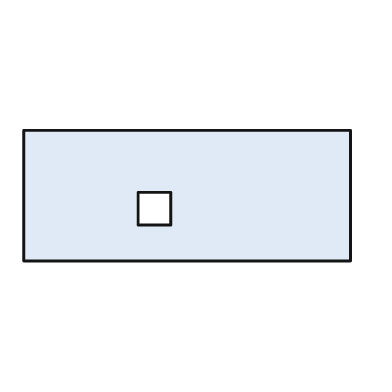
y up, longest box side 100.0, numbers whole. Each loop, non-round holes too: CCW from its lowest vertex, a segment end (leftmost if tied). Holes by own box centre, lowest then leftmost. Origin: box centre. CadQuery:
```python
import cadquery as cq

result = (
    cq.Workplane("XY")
    .moveTo(-50.0, -20.0)
    .lineTo(50.0, -20.0)
    .lineTo(50.0, 20.0)
    .lineTo(-50.0, 20.0)
    .close()
    .moveTo(-15.0, -9.0)
    .lineTo(-5.0, -9.0)
    .lineTo(-5.0, 1.0)
    .lineTo(-15.0, 1.0)
    .close()
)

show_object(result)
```